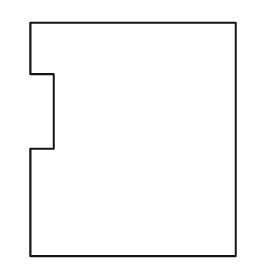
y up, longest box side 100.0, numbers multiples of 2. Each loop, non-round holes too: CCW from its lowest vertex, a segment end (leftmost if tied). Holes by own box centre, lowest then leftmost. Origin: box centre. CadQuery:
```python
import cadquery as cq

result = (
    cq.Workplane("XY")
    .moveTo(-44.0, -50.0)
    .lineTo(44.0, -50.0)
    .lineTo(44.0, 50.0)
    .lineTo(-44.0, 50.0)
    .lineTo(-44.0, 28.0)
    .lineTo(-34.0, 28.0)
    .lineTo(-34.0, -4.0)
    .lineTo(-44.0, -4.0)
    .close()
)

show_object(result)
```